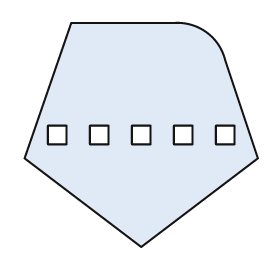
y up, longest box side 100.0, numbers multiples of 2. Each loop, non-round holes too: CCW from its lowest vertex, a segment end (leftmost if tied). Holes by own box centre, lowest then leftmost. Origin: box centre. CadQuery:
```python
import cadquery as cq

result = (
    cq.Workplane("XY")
    .moveTo(0.0, -48.0)
    .lineTo(50.0, -10.0)
    .lineTo(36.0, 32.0)
    .threePointArc((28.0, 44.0), (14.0, 48.0))
    .lineTo(-30.0, 48.0)
    .lineTo(-50.0, -10.0)
    .close()
    .moveTo(-40.0, -4.0)
    .lineTo(-32.0, -4.0)
    .lineTo(-32.0, 4.0)
    .lineTo(-40.0, 4.0)
    .close()
    .moveTo(-22.0, -4.0)
    .lineTo(-14.0, -4.0)
    .lineTo(-14.0, 4.0)
    .lineTo(-22.0, 4.0)
    .close()
    .moveTo(-4.0, -4.0)
    .lineTo(4.0, -4.0)
    .lineTo(4.0, 4.0)
    .lineTo(-4.0, 4.0)
    .close()
    .moveTo(14.0, -4.0)
    .lineTo(22.0, -4.0)
    .lineTo(22.0, 4.0)
    .lineTo(14.0, 4.0)
    .close()
    .moveTo(32.0, -4.0)
    .lineTo(40.0, -4.0)
    .lineTo(40.0, 4.0)
    .lineTo(32.0, 4.0)
    .close()
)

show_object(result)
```